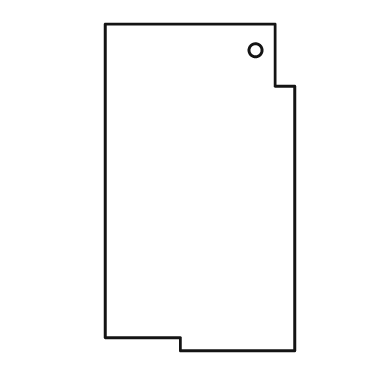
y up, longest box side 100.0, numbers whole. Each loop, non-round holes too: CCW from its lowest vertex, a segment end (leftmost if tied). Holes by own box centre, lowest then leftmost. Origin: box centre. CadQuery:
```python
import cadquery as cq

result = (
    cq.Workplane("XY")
    .moveTo(-6.0, -50.0)
    .lineTo(29.0, -50.0)
    .lineTo(29.0, 31.0)
    .lineTo(23.0, 31.0)
    .lineTo(23.0, 50.0)
    .lineTo(-29.0, 50.0)
    .lineTo(-29.0, -46.0)
    .lineTo(-6.0, -46.0)
    .close()
    .moveTo(17.0, 42.0)
    .circle(2.0)
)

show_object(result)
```